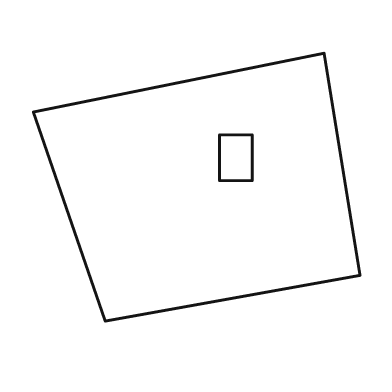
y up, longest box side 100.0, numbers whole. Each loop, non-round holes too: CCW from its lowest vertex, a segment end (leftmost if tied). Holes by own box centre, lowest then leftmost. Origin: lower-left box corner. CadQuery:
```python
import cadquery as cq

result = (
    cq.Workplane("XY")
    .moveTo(22.0, 0.0)
    .lineTo(100.0, 14.0)
    .lineTo(89.0, 82.0)
    .lineTo(0.0, 64.0)
    .close()
    .moveTo(57.0, 43.0)
    .lineTo(67.0, 43.0)
    .lineTo(67.0, 57.0)
    .lineTo(57.0, 57.0)
    .close()
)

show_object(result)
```